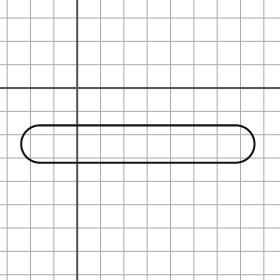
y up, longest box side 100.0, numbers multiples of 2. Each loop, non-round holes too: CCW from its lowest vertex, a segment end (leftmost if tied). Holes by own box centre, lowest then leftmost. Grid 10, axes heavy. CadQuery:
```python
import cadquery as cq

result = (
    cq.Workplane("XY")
    .moveTo(-16.0, -32.0)
    .lineTo(68.0, -32.0)
    .threePointArc((76.0, -24.0), (68.0, -16.0))
    .lineTo(-16.0, -16.0)
    .threePointArc((-24.0, -24.0), (-16.0, -32.0))
    .close()
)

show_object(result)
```